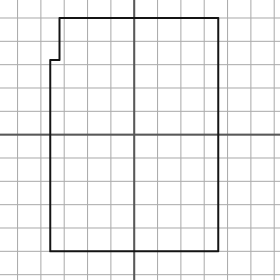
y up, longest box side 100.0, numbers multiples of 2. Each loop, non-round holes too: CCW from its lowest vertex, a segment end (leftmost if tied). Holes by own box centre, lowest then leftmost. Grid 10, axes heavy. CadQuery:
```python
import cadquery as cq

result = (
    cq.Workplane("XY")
    .moveTo(-36.0, -50.0)
    .lineTo(36.0, -50.0)
    .lineTo(36.0, 50.0)
    .lineTo(-32.0, 50.0)
    .lineTo(-32.0, 32.0)
    .lineTo(-36.0, 32.0)
    .close()
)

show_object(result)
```